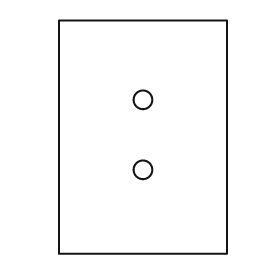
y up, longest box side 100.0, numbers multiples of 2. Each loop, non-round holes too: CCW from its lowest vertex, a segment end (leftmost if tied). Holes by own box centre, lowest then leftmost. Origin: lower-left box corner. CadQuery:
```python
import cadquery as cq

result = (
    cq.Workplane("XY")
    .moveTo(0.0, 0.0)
    .lineTo(72.0, 0.0)
    .lineTo(72.0, 100.0)
    .lineTo(0.0, 100.0)
    .close()
    .moveTo(36.0, 36.0)
    .circle(4.0)
    .moveTo(36.0, 66.0)
    .circle(4.0)
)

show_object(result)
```